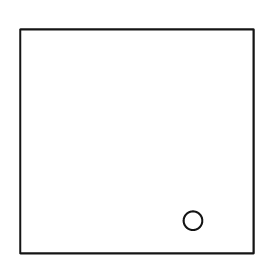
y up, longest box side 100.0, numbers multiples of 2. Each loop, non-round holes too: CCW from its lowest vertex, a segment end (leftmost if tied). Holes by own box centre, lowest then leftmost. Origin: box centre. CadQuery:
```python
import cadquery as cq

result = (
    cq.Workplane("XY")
    .moveTo(-50.0, -48.0)
    .lineTo(50.0, -48.0)
    .lineTo(50.0, 48.0)
    .lineTo(-50.0, 48.0)
    .close()
    .moveTo(24.0, -34.0)
    .circle(4.0)
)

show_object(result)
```